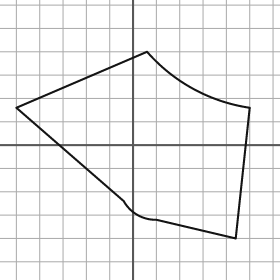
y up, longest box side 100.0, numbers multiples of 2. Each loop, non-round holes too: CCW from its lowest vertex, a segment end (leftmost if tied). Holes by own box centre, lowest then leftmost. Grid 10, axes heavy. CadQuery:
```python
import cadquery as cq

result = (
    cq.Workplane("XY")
    .moveTo(44.0, -40.0)
    .lineTo(50.0, 16.0)
    .threePointArc((26.0, 24.0), (6.0, 40.0))
    .lineTo(-50.0, 16.0)
    .lineTo(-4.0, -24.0)
    .threePointArc((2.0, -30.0), (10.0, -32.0))
    .close()
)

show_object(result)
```